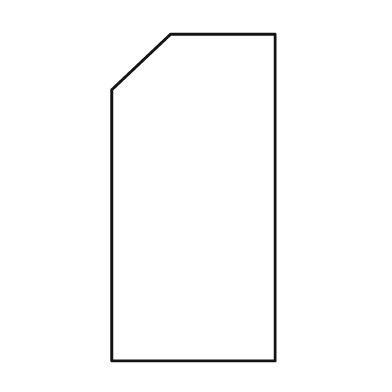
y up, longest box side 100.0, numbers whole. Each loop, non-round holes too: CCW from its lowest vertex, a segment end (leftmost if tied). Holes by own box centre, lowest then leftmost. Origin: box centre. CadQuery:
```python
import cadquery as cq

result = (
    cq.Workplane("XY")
    .moveTo(-25.0, -50.0)
    .lineTo(25.0, -50.0)
    .lineTo(25.0, 50.0)
    .lineTo(-7.0, 50.0)
    .lineTo(-25.0, 33.0)
    .close()
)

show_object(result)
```